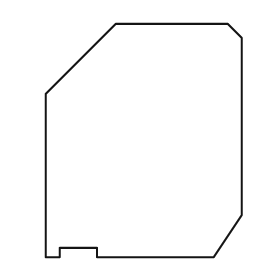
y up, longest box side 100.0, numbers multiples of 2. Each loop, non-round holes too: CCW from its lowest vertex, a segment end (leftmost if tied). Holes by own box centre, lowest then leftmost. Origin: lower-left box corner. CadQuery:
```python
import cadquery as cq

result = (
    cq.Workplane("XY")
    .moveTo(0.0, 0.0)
    .lineTo(6.0, 0.0)
    .lineTo(6.0, 4.0)
    .lineTo(22.0, 4.0)
    .lineTo(22.0, 0.0)
    .lineTo(72.0, 0.0)
    .lineTo(84.0, 18.0)
    .lineTo(84.0, 94.0)
    .lineTo(78.0, 100.0)
    .lineTo(30.0, 100.0)
    .lineTo(0.0, 70.0)
    .close()
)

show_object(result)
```